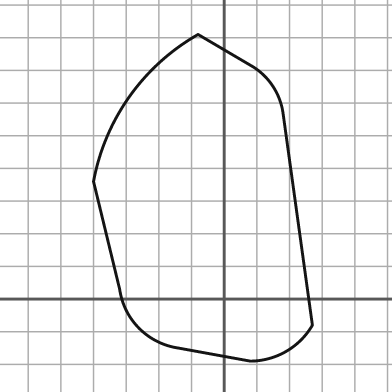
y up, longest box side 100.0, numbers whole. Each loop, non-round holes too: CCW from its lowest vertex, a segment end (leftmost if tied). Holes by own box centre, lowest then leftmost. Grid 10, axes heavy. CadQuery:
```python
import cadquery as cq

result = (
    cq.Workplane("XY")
    .moveTo(8.0, -19.0)
    .threePointArc((19.0, -16.0), (27.0, -8.0))
    .lineTo(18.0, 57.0)
    .threePointArc((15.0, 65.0), (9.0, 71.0))
    .lineTo(-8.0, 81.0)
    .threePointArc((-29.0, 62.0), (-40.0, 36.0))
    .lineTo(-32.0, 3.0)
    .threePointArc((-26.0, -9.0), (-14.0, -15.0))
    .close()
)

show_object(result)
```